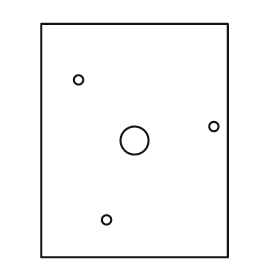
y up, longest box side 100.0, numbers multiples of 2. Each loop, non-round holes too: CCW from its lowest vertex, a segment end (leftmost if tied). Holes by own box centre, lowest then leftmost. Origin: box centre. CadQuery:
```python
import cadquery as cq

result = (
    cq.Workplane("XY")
    .moveTo(-40.0, -50.0)
    .lineTo(40.0, -50.0)
    .lineTo(40.0, 50.0)
    .lineTo(-40.0, 50.0)
    .close()
    .moveTo(-12.0, -34.0)
    .circle(2.0)
    .moveTo(0.0, 0.0)
    .circle(6.0)
    .moveTo(34.0, 6.0)
    .circle(2.0)
    .moveTo(-24.0, 26.0)
    .circle(2.0)
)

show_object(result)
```